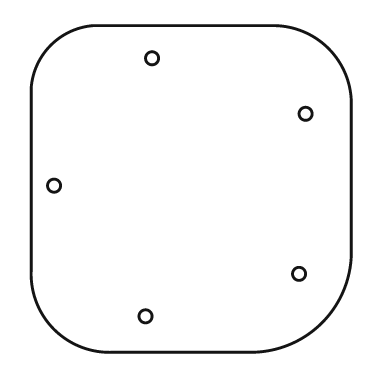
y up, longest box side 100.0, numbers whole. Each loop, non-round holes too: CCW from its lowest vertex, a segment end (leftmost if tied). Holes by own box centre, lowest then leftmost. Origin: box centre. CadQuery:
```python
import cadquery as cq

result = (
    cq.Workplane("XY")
    .moveTo(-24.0, -50.0)
    .lineTo(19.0, -50.0)
    .threePointArc((40.0, -41.0), (49.0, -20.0))
    .lineTo(49.0, 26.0)
    .threePointArc((42.0, 43.0), (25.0, 50.0))
    .lineTo(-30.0, 50.0)
    .threePointArc((-43.0, 44.0), (-49.0, 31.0))
    .lineTo(-49.0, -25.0)
    .threePointArc((-42.0, -43.0), (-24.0, -50.0))
    .close()
    .moveTo(-14.0, -39.0)
    .circle(2.0)
    .moveTo(33.0, -26.0)
    .circle(2.0)
    .moveTo(-42.0, 1.0)
    .circle(2.0)
    .moveTo(35.0, 23.0)
    .circle(2.0)
    .moveTo(-12.0, 40.0)
    .circle(2.0)
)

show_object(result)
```